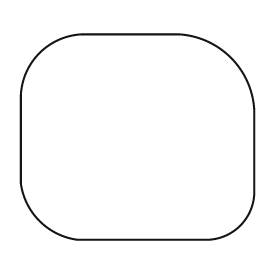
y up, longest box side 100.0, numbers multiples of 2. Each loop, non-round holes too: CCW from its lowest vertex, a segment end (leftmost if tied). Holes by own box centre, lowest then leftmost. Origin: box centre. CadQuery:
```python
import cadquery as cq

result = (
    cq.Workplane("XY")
    .moveTo(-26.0, -44.0)
    .lineTo(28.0, -44.0)
    .threePointArc((44.0, -38.0), (50.0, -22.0))
    .lineTo(50.0, 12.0)
    .threePointArc((40.0, 34.0), (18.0, 44.0))
    .lineTo(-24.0, 44.0)
    .threePointArc((-42.0, 36.0), (-50.0, 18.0))
    .lineTo(-50.0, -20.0)
    .threePointArc((-42.0, -36.0), (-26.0, -44.0))
    .close()
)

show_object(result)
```